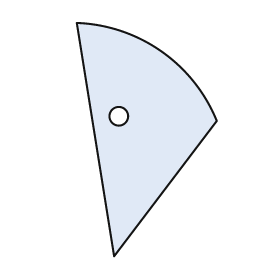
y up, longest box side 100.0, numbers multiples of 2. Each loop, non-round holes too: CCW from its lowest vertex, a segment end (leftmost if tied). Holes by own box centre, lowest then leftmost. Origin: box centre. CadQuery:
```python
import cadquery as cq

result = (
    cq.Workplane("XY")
    .moveTo(-14.0, -50.0)
    .lineTo(30.0, 8.0)
    .threePointArc((6.0, 38.0), (-30.0, 50.0))
    .close()
    .moveTo(-12.0, 10.0)
    .circle(4.0)
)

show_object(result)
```